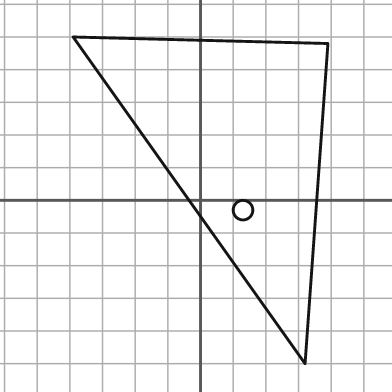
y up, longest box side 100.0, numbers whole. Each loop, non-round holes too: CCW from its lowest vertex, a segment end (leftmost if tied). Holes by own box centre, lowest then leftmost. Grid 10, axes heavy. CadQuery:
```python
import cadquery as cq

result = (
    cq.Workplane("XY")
    .moveTo(32.0, -50.0)
    .lineTo(39.0, 48.0)
    .lineTo(-39.0, 50.0)
    .close()
    .moveTo(13.0, -3.0)
    .circle(3.0)
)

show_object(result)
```